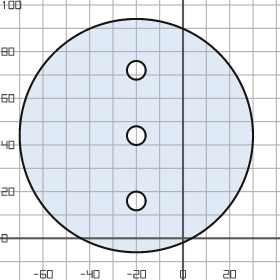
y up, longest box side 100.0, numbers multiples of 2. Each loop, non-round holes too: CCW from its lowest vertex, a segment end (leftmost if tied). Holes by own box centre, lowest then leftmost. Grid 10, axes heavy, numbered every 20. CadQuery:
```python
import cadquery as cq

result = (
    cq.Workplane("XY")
    .moveTo(-20.0, 44.0)
    .circle(50.0)
    .moveTo(-20.0, 16.0)
    .circle(4.0)
    .moveTo(-20.0, 44.0)
    .circle(4.0)
    .moveTo(-20.0, 72.0)
    .circle(4.0)
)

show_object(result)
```